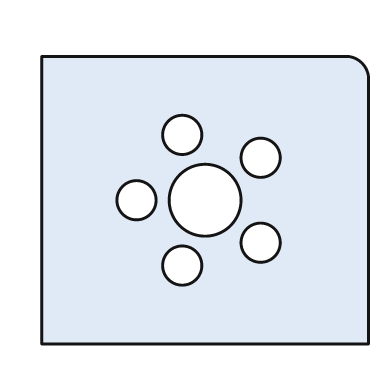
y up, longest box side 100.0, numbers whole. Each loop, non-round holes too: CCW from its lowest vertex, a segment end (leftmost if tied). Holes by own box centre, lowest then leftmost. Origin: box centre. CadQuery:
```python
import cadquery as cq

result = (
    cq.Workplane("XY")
    .moveTo(-50.0, -44.0)
    .lineTo(50.0, -44.0)
    .lineTo(50.0, 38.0)
    .threePointArc((48.0, 42.0), (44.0, 44.0))
    .lineTo(-50.0, 44.0)
    .close()
    .moveTo(-7.0, -20.0)
    .circle(6.0)
    .moveTo(17.0, -13.0)
    .circle(6.0)
    .moveTo(-21.0, 0.0)
    .circle(6.0)
    .moveTo(0.0, 0.0)
    .circle(11.0)
    .moveTo(17.0, 13.0)
    .circle(6.0)
    .moveTo(-7.0, 20.0)
    .circle(6.0)
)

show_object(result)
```